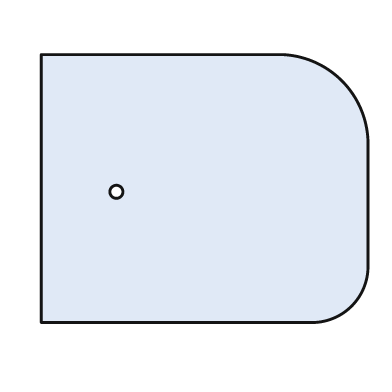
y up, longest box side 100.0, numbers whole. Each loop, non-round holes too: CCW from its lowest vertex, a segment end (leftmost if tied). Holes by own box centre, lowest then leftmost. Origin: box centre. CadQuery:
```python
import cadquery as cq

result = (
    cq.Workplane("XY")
    .moveTo(-50.0, -41.0)
    .lineTo(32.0, -41.0)
    .threePointArc((45.0, -36.0), (50.0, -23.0))
    .lineTo(50.0, 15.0)
    .threePointArc((42.0, 33.0), (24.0, 41.0))
    .lineTo(-50.0, 41.0)
    .close()
    .moveTo(-27.0, -1.0)
    .circle(2.0)
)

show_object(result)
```